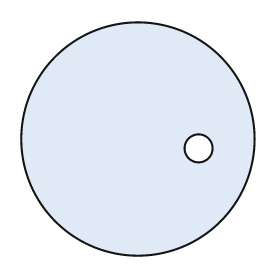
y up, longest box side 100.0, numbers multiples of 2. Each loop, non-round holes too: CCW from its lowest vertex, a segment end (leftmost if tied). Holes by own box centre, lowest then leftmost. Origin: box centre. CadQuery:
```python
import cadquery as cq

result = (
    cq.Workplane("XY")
    .moveTo(0.0, 0.0)
    .circle(50.0)
    .moveTo(26.0, -4.0)
    .circle(6.0)
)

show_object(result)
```